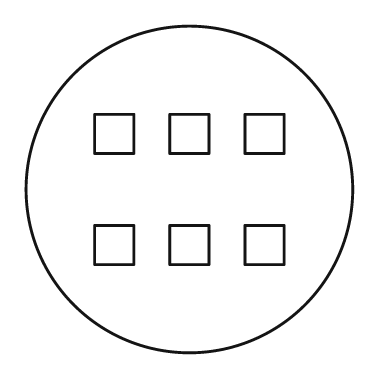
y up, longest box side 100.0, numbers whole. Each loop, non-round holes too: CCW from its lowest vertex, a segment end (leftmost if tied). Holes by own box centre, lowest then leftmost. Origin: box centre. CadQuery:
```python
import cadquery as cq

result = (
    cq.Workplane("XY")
    .moveTo(0.0, 0.0)
    .circle(50.0)
    .moveTo(-29.0, -23.0)
    .lineTo(-17.0, -23.0)
    .lineTo(-17.0, -11.0)
    .lineTo(-29.0, -11.0)
    .close()
    .moveTo(-6.0, -23.0)
    .lineTo(6.0, -23.0)
    .lineTo(6.0, -11.0)
    .lineTo(-6.0, -11.0)
    .close()
    .moveTo(17.0, -23.0)
    .lineTo(29.0, -23.0)
    .lineTo(29.0, -11.0)
    .lineTo(17.0, -11.0)
    .close()
    .moveTo(-29.0, 11.0)
    .lineTo(-17.0, 11.0)
    .lineTo(-17.0, 23.0)
    .lineTo(-29.0, 23.0)
    .close()
    .moveTo(-6.0, 11.0)
    .lineTo(6.0, 11.0)
    .lineTo(6.0, 23.0)
    .lineTo(-6.0, 23.0)
    .close()
    .moveTo(17.0, 11.0)
    .lineTo(29.0, 11.0)
    .lineTo(29.0, 23.0)
    .lineTo(17.0, 23.0)
    .close()
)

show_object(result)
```